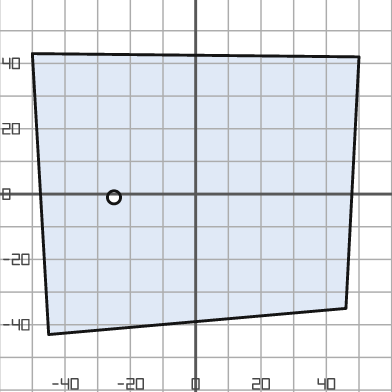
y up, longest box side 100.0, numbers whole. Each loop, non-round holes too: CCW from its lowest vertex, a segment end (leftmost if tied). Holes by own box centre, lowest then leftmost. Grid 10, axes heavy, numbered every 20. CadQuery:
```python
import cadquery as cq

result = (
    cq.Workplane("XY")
    .moveTo(-45.0, -43.0)
    .lineTo(46.0, -35.0)
    .lineTo(50.0, 42.0)
    .lineTo(-50.0, 43.0)
    .close()
    .moveTo(-25.0, -1.0)
    .circle(2.0)
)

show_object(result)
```